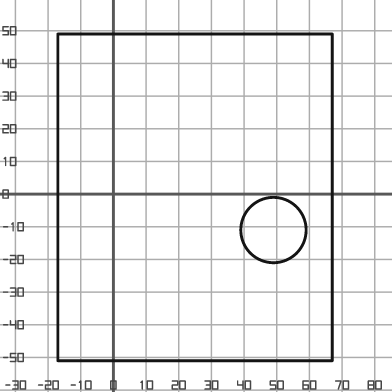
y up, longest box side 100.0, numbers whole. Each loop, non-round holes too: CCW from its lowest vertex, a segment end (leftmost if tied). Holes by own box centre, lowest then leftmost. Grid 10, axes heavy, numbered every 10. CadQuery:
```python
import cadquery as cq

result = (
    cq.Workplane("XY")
    .moveTo(-17.0, -51.0)
    .lineTo(67.0, -51.0)
    .lineTo(67.0, 49.0)
    .lineTo(-17.0, 49.0)
    .close()
    .moveTo(49.0, -11.0)
    .circle(10.0)
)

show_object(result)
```